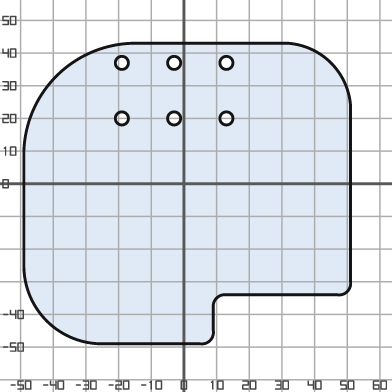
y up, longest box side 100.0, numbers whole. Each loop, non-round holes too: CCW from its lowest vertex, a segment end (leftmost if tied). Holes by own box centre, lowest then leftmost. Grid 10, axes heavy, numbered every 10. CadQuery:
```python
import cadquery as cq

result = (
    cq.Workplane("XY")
    .moveTo(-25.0, -49.0)
    .lineTo(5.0, -49.0)
    .threePointArc((8.0, -48.0), (9.0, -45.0))
    .lineTo(9.0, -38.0)
    .threePointArc((10.0, -35.0), (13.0, -34.0))
    .lineTo(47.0, -34.0)
    .threePointArc((50.0, -33.0), (51.0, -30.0))
    .lineTo(51.0, 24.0)
    .threePointArc((45.0, 37.0), (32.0, 43.0))
    .lineTo(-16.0, 43.0)
    .threePointArc((-39.0, 33.0), (-49.0, 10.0))
    .lineTo(-49.0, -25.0)
    .threePointArc((-42.0, -42.0), (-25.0, -49.0))
    .close()
    .moveTo(-19.0, 20.0)
    .circle(2.0)
    .moveTo(-3.0, 20.0)
    .circle(2.0)
    .moveTo(13.0, 20.0)
    .circle(2.0)
    .moveTo(-19.0, 37.0)
    .circle(2.0)
    .moveTo(-3.0, 37.0)
    .circle(2.0)
    .moveTo(13.0, 37.0)
    .circle(2.0)
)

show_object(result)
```